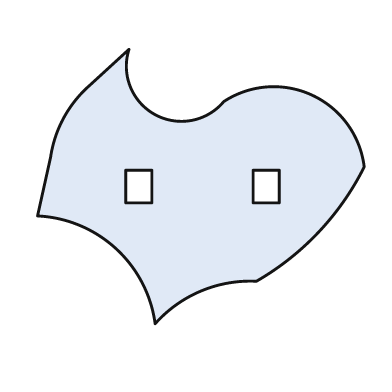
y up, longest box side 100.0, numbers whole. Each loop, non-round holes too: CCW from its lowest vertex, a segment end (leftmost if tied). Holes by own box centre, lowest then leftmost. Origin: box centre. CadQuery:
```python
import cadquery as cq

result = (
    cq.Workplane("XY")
    .moveTo(-14.0, -42.0)
    .threePointArc((0.0, -32.0), (17.0, -29.0))
    .threePointArc((36.0, -14.0), (50.0, 6.0))
    .threePointArc((34.0, 28.0), (7.0, 26.0))
    .threePointArc((-14.0, 22.0), (-22.0, 42.0))
    .lineTo(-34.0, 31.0)
    .threePointArc((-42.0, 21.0), (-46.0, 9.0))
    .lineTo(-50.0, -9.0)
    .threePointArc((-26.0, -19.0), (-14.0, -42.0))
    .close()
    .moveTo(-23.0, -5.0)
    .lineTo(-15.0, -5.0)
    .lineTo(-15.0, 5.0)
    .lineTo(-23.0, 5.0)
    .close()
    .moveTo(16.0, -5.0)
    .lineTo(24.0, -5.0)
    .lineTo(24.0, 5.0)
    .lineTo(16.0, 5.0)
    .close()
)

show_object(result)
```